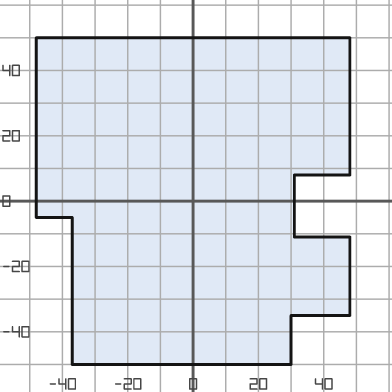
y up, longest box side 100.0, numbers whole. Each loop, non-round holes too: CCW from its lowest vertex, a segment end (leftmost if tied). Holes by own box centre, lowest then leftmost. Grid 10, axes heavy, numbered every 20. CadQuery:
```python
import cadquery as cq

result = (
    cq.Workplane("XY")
    .moveTo(-37.0, -50.0)
    .lineTo(30.0, -50.0)
    .lineTo(30.0, -35.0)
    .lineTo(48.0, -35.0)
    .lineTo(48.0, -11.0)
    .lineTo(31.0, -11.0)
    .lineTo(31.0, 8.0)
    .lineTo(48.0, 8.0)
    .lineTo(48.0, 50.0)
    .lineTo(-48.0, 50.0)
    .lineTo(-48.0, -5.0)
    .lineTo(-37.0, -5.0)
    .close()
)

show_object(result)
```